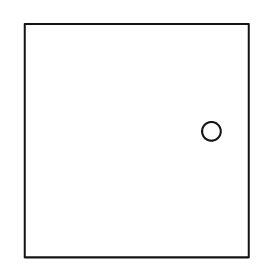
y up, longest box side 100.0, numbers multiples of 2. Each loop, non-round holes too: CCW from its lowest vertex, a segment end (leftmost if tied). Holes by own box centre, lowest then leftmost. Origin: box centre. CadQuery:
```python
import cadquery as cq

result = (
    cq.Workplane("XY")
    .moveTo(-48.0, -50.0)
    .lineTo(48.0, -50.0)
    .lineTo(48.0, 50.0)
    .lineTo(-48.0, 50.0)
    .close()
    .moveTo(32.0, 4.0)
    .circle(4.0)
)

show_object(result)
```